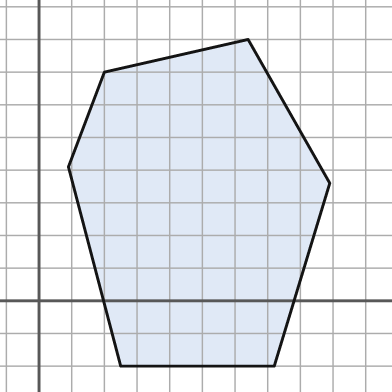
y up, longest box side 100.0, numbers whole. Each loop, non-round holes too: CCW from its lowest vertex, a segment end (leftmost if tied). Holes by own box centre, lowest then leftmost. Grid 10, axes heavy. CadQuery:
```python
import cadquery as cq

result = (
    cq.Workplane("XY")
    .moveTo(25.0, -20.0)
    .lineTo(72.0, -20.0)
    .lineTo(89.0, 36.0)
    .lineTo(64.0, 80.0)
    .lineTo(20.0, 70.0)
    .lineTo(9.0, 41.0)
    .close()
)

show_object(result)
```